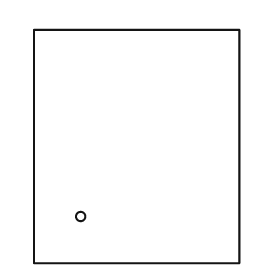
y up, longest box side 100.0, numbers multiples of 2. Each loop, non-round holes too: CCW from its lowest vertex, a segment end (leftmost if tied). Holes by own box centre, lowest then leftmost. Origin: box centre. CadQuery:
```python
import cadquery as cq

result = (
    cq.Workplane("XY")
    .moveTo(-44.0, -50.0)
    .lineTo(44.0, -50.0)
    .lineTo(44.0, 50.0)
    .lineTo(-44.0, 50.0)
    .close()
    .moveTo(-24.0, -30.0)
    .circle(2.0)
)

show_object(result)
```